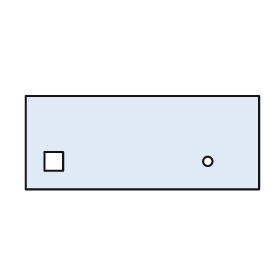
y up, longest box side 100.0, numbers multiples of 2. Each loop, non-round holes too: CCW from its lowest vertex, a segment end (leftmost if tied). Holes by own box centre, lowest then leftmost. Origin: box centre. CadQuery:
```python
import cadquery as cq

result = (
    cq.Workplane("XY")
    .moveTo(-50.0, -20.0)
    .lineTo(50.0, -20.0)
    .lineTo(50.0, 20.0)
    .lineTo(-50.0, 20.0)
    .close()
    .moveTo(-42.0, -12.0)
    .lineTo(-34.0, -12.0)
    .lineTo(-34.0, -4.0)
    .lineTo(-42.0, -4.0)
    .close()
    .moveTo(28.0, -8.0)
    .circle(2.0)
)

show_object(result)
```